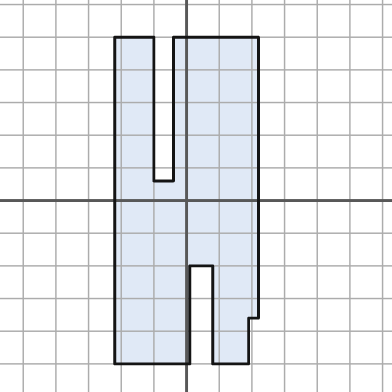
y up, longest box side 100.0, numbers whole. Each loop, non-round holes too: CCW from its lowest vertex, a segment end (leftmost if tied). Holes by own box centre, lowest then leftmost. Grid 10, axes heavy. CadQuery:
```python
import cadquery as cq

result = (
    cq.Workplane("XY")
    .moveTo(-22.0, -50.0)
    .lineTo(1.0, -50.0)
    .lineTo(1.0, -20.0)
    .lineTo(8.0, -20.0)
    .lineTo(8.0, -50.0)
    .lineTo(19.0, -50.0)
    .lineTo(19.0, -36.0)
    .lineTo(22.0, -36.0)
    .lineTo(22.0, 50.0)
    .lineTo(-4.0, 50.0)
    .lineTo(-4.0, 6.0)
    .lineTo(-10.0, 6.0)
    .lineTo(-10.0, 50.0)
    .lineTo(-22.0, 50.0)
    .close()
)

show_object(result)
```